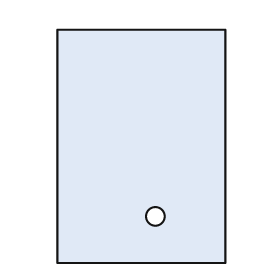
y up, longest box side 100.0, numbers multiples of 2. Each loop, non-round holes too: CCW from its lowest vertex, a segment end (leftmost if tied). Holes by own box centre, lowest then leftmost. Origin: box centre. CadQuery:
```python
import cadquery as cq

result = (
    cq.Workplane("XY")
    .moveTo(-36.0, -50.0)
    .lineTo(36.0, -50.0)
    .lineTo(36.0, 50.0)
    .lineTo(-36.0, 50.0)
    .close()
    .moveTo(6.0, -30.0)
    .circle(4.0)
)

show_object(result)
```